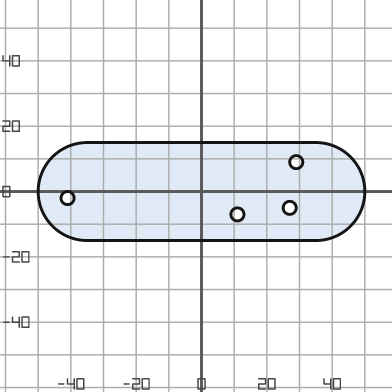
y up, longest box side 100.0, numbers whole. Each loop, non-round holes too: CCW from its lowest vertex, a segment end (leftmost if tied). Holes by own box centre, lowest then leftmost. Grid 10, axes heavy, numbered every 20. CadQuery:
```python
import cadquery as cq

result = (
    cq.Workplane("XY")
    .moveTo(-35.0, -15.0)
    .lineTo(35.0, -15.0)
    .threePointArc((50.0, 0.0), (35.0, 15.0))
    .lineTo(-35.0, 15.0)
    .threePointArc((-50.0, 0.0), (-35.0, -15.0))
    .close()
    .moveTo(11.0, -7.0)
    .circle(2.0)
    .moveTo(27.0, -5.0)
    .circle(2.0)
    .moveTo(-41.0, -2.0)
    .circle(2.0)
    .moveTo(29.0, 9.0)
    .circle(2.0)
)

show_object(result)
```